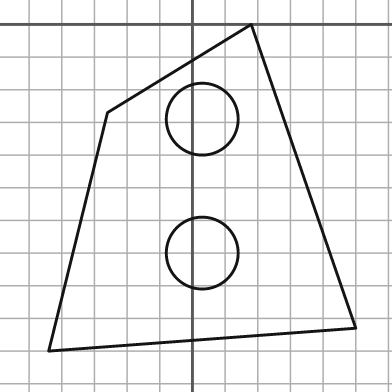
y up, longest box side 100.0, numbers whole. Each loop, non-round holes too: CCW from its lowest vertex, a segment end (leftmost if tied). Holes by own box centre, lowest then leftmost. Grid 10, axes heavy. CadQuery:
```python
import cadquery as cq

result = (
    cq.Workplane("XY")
    .moveTo(-44.0, -100.0)
    .lineTo(50.0, -93.0)
    .lineTo(18.0, 0.0)
    .lineTo(-26.0, -27.0)
    .close()
    .moveTo(3.0, -70.0)
    .circle(11.0)
    .moveTo(3.0, -29.0)
    .circle(11.0)
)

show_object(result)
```